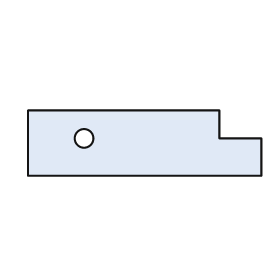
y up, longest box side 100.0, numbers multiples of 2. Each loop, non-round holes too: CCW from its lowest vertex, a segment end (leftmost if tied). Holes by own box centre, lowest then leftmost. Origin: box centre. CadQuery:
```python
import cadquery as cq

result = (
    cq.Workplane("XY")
    .moveTo(-50.0, -14.0)
    .lineTo(50.0, -14.0)
    .lineTo(50.0, 2.0)
    .lineTo(32.0, 2.0)
    .lineTo(32.0, 14.0)
    .lineTo(-50.0, 14.0)
    .close()
    .moveTo(-26.0, 2.0)
    .circle(4.0)
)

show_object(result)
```